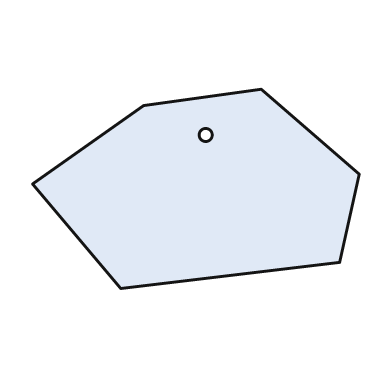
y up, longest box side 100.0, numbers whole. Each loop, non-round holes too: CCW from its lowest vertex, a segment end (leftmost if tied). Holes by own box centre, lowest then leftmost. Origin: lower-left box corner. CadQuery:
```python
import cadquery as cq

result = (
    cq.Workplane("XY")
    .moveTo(27.0, 0.0)
    .lineTo(94.0, 8.0)
    .lineTo(100.0, 35.0)
    .lineTo(70.0, 61.0)
    .lineTo(34.0, 56.0)
    .lineTo(0.0, 32.0)
    .close()
    .moveTo(53.0, 47.0)
    .circle(2.0)
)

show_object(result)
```